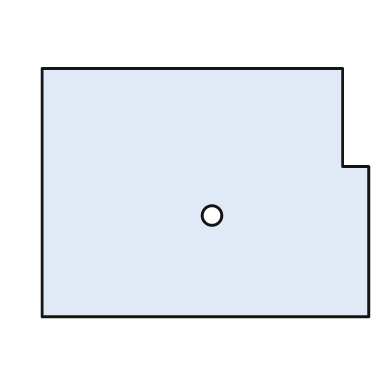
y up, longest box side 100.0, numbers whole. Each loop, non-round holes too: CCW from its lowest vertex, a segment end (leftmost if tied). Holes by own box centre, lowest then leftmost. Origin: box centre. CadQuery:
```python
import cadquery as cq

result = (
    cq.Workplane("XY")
    .moveTo(-50.0, -38.0)
    .lineTo(50.0, -38.0)
    .lineTo(50.0, 8.0)
    .lineTo(42.0, 8.0)
    .lineTo(42.0, 38.0)
    .lineTo(-50.0, 38.0)
    .close()
    .moveTo(2.0, -7.0)
    .circle(3.0)
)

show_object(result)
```